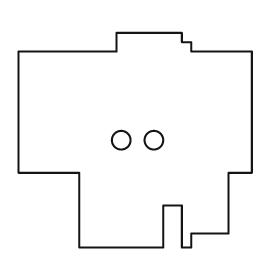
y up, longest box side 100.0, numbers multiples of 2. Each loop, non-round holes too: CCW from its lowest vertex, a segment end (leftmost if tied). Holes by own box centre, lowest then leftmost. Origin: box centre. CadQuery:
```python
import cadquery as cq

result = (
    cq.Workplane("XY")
    .moveTo(-24.0, -46.0)
    .lineTo(12.0, -46.0)
    .lineTo(12.0, -28.0)
    .lineTo(20.0, -28.0)
    .lineTo(20.0, -46.0)
    .lineTo(24.0, -46.0)
    .lineTo(24.0, -40.0)
    .lineTo(40.0, -40.0)
    .lineTo(40.0, -14.0)
    .lineTo(50.0, -14.0)
    .lineTo(50.0, 38.0)
    .lineTo(24.0, 38.0)
    .lineTo(24.0, 42.0)
    .lineTo(20.0, 42.0)
    .lineTo(20.0, 46.0)
    .lineTo(-8.0, 46.0)
    .lineTo(-8.0, 38.0)
    .lineTo(-50.0, 38.0)
    .lineTo(-50.0, -14.0)
    .lineTo(-24.0, -14.0)
    .close()
    .moveTo(-6.0, 0.0)
    .circle(4.0)
    .moveTo(8.0, 0.0)
    .circle(4.0)
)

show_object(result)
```